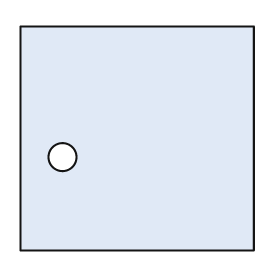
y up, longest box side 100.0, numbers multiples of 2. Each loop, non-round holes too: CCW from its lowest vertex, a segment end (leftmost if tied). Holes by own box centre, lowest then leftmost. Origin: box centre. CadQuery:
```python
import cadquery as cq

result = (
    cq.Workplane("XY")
    .moveTo(-50.0, -48.0)
    .lineTo(50.0, -48.0)
    .lineTo(50.0, 48.0)
    .lineTo(-50.0, 48.0)
    .close()
    .moveTo(-32.0, -8.0)
    .circle(6.0)
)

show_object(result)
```